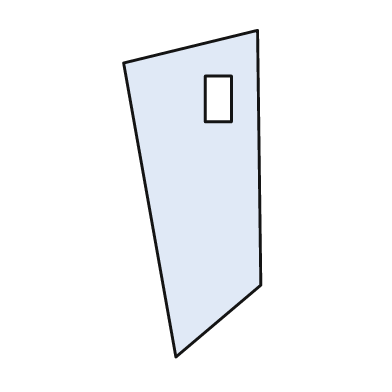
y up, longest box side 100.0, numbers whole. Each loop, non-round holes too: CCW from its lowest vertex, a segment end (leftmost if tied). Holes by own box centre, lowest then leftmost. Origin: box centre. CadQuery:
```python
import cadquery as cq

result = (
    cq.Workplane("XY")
    .moveTo(-5.0, -50.0)
    .lineTo(21.0, -28.0)
    .lineTo(20.0, 50.0)
    .lineTo(-21.0, 40.0)
    .close()
    .moveTo(4.0, 22.0)
    .lineTo(12.0, 22.0)
    .lineTo(12.0, 36.0)
    .lineTo(4.0, 36.0)
    .close()
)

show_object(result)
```